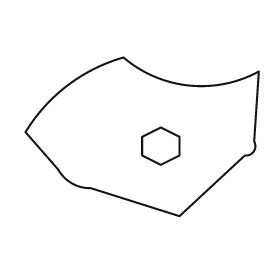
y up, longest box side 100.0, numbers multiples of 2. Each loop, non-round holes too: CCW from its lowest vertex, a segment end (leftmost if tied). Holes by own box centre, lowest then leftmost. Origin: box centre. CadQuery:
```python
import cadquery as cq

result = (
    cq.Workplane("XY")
    .moveTo(16.0, -34.0)
    .lineTo(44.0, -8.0)
    .threePointArc((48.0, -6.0), (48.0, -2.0))
    .lineTo(50.0, 28.0)
    .threePointArc((20.0, 22.0), (-8.0, 34.0))
    .threePointArc((-32.0, 22.0), (-50.0, 2.0))
    .lineTo(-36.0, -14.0)
    .threePointArc((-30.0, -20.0), (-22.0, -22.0))
    .close()
    .moveTo(8.0, -12.0)
    .lineTo(16.0, -8.0)
    .lineTo(16.0, 0.0)
    .lineTo(8.0, 4.0)
    .lineTo(0.0, 0.0)
    .lineTo(0.0, -8.0)
    .close()
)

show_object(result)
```